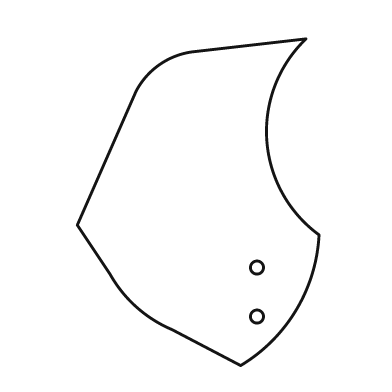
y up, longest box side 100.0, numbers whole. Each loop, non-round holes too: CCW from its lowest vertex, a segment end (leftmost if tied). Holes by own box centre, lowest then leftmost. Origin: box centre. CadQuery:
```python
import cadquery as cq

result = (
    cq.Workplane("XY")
    .moveTo(13.0, -50.0)
    .threePointArc((30.0, -33.0), (37.0, -10.0))
    .threePointArc((21.0, 19.0), (33.0, 50.0))
    .lineTo(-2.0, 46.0)
    .threePointArc((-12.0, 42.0), (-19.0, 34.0))
    .lineTo(-37.0, -7.0)
    .lineTo(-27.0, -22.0)
    .threePointArc((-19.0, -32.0), (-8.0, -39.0))
    .close()
    .moveTo(18.0, -35.0)
    .circle(2.0)
    .moveTo(18.0, -20.0)
    .circle(2.0)
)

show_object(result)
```